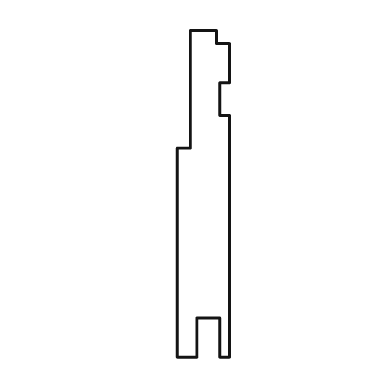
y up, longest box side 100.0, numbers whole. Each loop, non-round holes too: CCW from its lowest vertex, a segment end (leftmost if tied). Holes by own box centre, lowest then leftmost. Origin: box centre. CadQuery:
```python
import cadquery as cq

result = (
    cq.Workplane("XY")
    .moveTo(-8.0, -50.0)
    .lineTo(-2.0, -50.0)
    .lineTo(-2.0, -38.0)
    .lineTo(5.0, -38.0)
    .lineTo(5.0, -50.0)
    .lineTo(8.0, -50.0)
    .lineTo(8.0, 24.0)
    .lineTo(5.0, 24.0)
    .lineTo(5.0, 34.0)
    .lineTo(8.0, 34.0)
    .lineTo(8.0, 46.0)
    .lineTo(4.0, 46.0)
    .lineTo(4.0, 50.0)
    .lineTo(-4.0, 50.0)
    .lineTo(-4.0, 14.0)
    .lineTo(-8.0, 14.0)
    .close()
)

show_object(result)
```